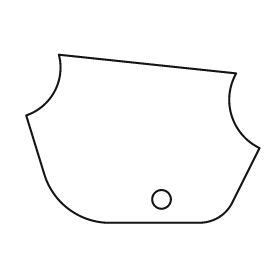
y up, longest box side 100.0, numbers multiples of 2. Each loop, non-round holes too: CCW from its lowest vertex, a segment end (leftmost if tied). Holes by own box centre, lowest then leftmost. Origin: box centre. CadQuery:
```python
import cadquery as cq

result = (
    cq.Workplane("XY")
    .moveTo(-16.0, -36.0)
    .lineTo(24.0, -36.0)
    .threePointArc((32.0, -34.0), (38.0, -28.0))
    .lineTo(50.0, -4.0)
    .threePointArc((38.0, 10.0), (40.0, 28.0))
    .lineTo(-36.0, 36.0)
    .threePointArc((-38.0, 20.0), (-50.0, 10.0))
    .lineTo(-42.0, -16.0)
    .threePointArc((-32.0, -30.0), (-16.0, -36.0))
    .close()
    .moveTo(8.0, -26.0)
    .circle(4.0)
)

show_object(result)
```